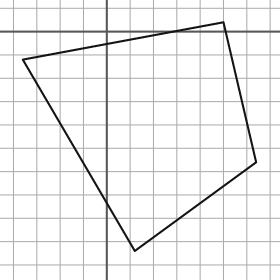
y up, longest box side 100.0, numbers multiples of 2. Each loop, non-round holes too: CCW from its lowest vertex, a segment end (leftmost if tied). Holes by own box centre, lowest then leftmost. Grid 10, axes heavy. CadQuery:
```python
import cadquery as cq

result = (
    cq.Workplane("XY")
    .moveTo(12.0, -94.0)
    .lineTo(64.0, -56.0)
    .lineTo(50.0, 4.0)
    .lineTo(-36.0, -12.0)
    .close()
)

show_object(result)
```